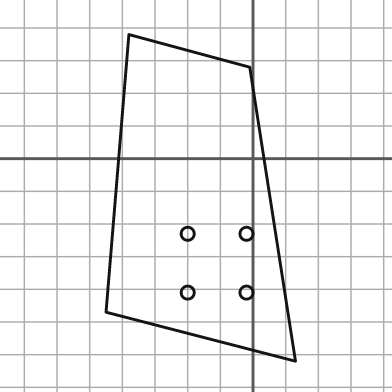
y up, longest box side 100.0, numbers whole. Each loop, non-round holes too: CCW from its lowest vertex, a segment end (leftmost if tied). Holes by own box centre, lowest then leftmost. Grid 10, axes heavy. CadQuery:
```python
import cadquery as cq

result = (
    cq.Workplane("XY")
    .moveTo(13.0, -62.0)
    .lineTo(-1.0, 28.0)
    .lineTo(-38.0, 38.0)
    .lineTo(-45.0, -47.0)
    .close()
    .moveTo(-20.0, -41.0)
    .circle(2.0)
    .moveTo(-2.0, -41.0)
    .circle(2.0)
    .moveTo(-20.0, -23.0)
    .circle(2.0)
    .moveTo(-2.0, -23.0)
    .circle(2.0)
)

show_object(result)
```